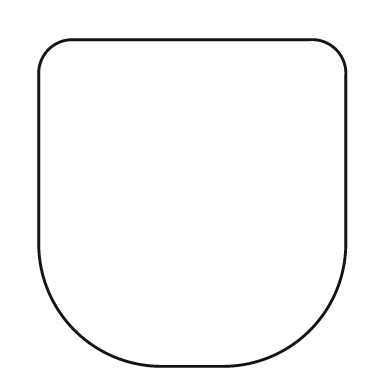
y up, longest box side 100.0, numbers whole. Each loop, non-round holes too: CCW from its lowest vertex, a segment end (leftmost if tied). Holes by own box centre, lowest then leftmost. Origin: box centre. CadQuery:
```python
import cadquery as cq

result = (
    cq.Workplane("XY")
    .moveTo(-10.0, -50.0)
    .lineTo(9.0, -50.0)
    .threePointArc((36.0, -39.0), (47.0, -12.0))
    .lineTo(47.0, 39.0)
    .threePointArc((44.0, 47.0), (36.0, 50.0))
    .lineTo(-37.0, 50.0)
    .threePointArc((-44.0, 47.0), (-47.0, 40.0))
    .lineTo(-47.0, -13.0)
    .threePointArc((-36.0, -39.0), (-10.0, -50.0))
    .close()
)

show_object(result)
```